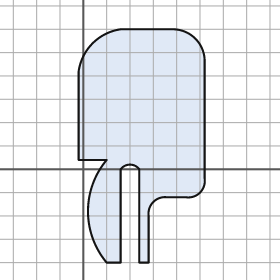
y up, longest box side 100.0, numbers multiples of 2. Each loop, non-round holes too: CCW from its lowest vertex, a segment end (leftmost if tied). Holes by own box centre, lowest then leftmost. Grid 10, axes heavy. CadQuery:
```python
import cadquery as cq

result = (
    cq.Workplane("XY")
    .moveTo(10.0, -40.0)
    .lineTo(16.0, -40.0)
    .lineTo(16.0, 0.0)
    .threePointArc((20.0, 2.0), (24.0, 0.0))
    .lineTo(24.0, -40.0)
    .lineTo(28.0, -40.0)
    .lineTo(28.0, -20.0)
    .threePointArc((30.0, -14.0), (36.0, -12.0))
    .lineTo(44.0, -12.0)
    .threePointArc((50.0, -10.0), (52.0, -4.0))
    .lineTo(52.0, 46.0)
    .threePointArc((48.0, 56.0), (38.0, 60.0))
    .lineTo(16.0, 60.0)
    .threePointArc((4.0, 54.0), (-2.0, 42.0))
    .lineTo(-2.0, 4.0)
    .lineTo(10.0, 4.0)
    .threePointArc((2.0, -18.0), (10.0, -40.0))
    .close()
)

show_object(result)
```